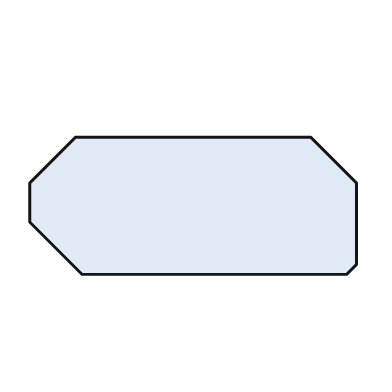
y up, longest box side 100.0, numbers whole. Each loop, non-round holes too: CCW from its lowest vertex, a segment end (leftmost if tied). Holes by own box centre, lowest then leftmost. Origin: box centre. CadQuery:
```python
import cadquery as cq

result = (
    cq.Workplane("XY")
    .moveTo(-34.0, -21.0)
    .lineTo(47.0, -21.0)
    .lineTo(50.0, -18.0)
    .lineTo(50.0, 7.0)
    .lineTo(36.0, 21.0)
    .lineTo(-36.0, 21.0)
    .lineTo(-50.0, 7.0)
    .lineTo(-50.0, -5.0)
    .close()
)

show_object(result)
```